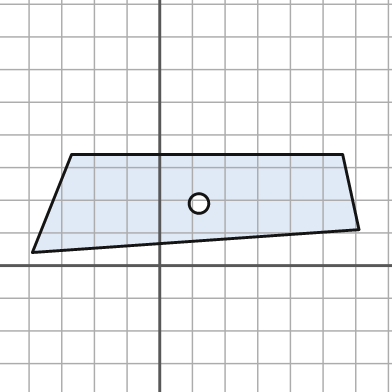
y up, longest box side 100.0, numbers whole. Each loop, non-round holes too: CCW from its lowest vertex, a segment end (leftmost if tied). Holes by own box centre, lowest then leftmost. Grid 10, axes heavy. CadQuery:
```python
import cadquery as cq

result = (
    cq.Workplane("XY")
    .moveTo(-39.0, 4.0)
    .lineTo(61.0, 11.0)
    .lineTo(56.0, 34.0)
    .lineTo(-27.0, 34.0)
    .close()
    .moveTo(12.0, 19.0)
    .circle(3.0)
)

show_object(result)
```